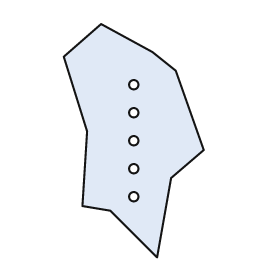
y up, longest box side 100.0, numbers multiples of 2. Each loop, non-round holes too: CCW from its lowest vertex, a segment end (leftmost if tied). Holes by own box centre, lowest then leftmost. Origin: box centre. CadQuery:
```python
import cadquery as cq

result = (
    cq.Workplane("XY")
    .moveTo(10.0, -50.0)
    .lineTo(16.0, -16.0)
    .lineTo(30.0, -4.0)
    .lineTo(18.0, 30.0)
    .lineTo(8.0, 38.0)
    .lineTo(-14.0, 50.0)
    .lineTo(-30.0, 36.0)
    .lineTo(-20.0, 4.0)
    .lineTo(-22.0, -28.0)
    .lineTo(-10.0, -30.0)
    .close()
    .moveTo(0.0, -24.0)
    .circle(2.0)
    .moveTo(0.0, -12.0)
    .circle(2.0)
    .moveTo(0.0, 0.0)
    .circle(2.0)
    .moveTo(0.0, 12.0)
    .circle(2.0)
    .moveTo(0.0, 24.0)
    .circle(2.0)
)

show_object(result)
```